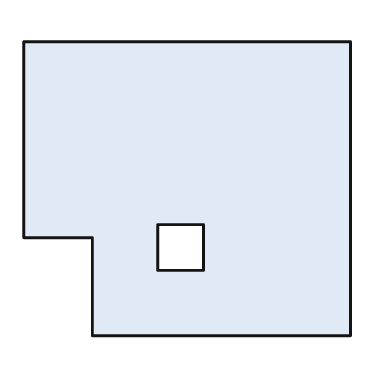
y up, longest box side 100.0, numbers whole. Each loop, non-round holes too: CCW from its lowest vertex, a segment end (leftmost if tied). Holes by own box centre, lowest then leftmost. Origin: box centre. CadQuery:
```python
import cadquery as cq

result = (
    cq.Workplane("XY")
    .moveTo(-29.0, -45.0)
    .lineTo(50.0, -45.0)
    .lineTo(50.0, 45.0)
    .lineTo(-50.0, 45.0)
    .lineTo(-50.0, -15.0)
    .lineTo(-29.0, -15.0)
    .close()
    .moveTo(-9.0, -25.0)
    .lineTo(5.0, -25.0)
    .lineTo(5.0, -11.0)
    .lineTo(-9.0, -11.0)
    .close()
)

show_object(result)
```